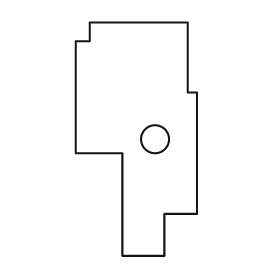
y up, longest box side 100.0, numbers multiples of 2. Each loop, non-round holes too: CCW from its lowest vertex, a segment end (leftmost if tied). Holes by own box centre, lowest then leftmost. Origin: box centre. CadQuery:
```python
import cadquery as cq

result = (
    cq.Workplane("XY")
    .moveTo(-6.0, -50.0)
    .lineTo(12.0, -50.0)
    .lineTo(12.0, -32.0)
    .lineTo(26.0, -32.0)
    .lineTo(26.0, 20.0)
    .lineTo(22.0, 20.0)
    .lineTo(22.0, 50.0)
    .lineTo(-20.0, 50.0)
    .lineTo(-20.0, 42.0)
    .lineTo(-26.0, 42.0)
    .lineTo(-26.0, -6.0)
    .lineTo(-6.0, -6.0)
    .close()
    .moveTo(8.0, 0.0)
    .circle(6.0)
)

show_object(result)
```